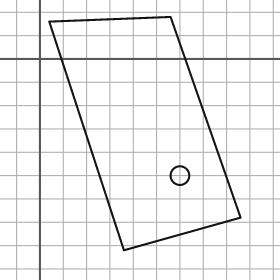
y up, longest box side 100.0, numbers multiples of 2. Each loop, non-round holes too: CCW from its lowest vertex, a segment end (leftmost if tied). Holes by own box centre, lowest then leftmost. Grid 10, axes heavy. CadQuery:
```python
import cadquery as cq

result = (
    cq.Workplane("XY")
    .moveTo(36.0, -82.0)
    .lineTo(86.0, -68.0)
    .lineTo(56.0, 18.0)
    .lineTo(4.0, 16.0)
    .close()
    .moveTo(60.0, -50.0)
    .circle(4.0)
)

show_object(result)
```